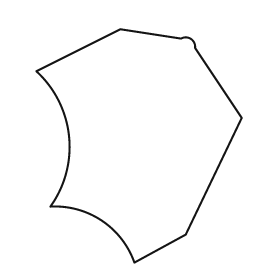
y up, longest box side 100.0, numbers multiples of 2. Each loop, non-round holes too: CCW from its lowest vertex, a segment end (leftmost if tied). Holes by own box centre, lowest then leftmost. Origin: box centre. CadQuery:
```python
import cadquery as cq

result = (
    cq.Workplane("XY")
    .moveTo(-2.0, -50.0)
    .lineTo(20.0, -38.0)
    .lineTo(44.0, 12.0)
    .lineTo(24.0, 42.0)
    .threePointArc((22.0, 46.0), (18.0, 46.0))
    .lineTo(-8.0, 50.0)
    .lineTo(-44.0, 32.0)
    .threePointArc((-30.0, 4.0), (-38.0, -26.0))
    .threePointArc((-16.0, -32.0), (-2.0, -50.0))
    .close()
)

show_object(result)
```